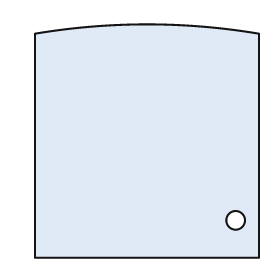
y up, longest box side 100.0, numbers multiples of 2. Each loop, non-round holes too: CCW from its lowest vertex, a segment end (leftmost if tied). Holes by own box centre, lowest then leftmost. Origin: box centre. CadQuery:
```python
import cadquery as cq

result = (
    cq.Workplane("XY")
    .moveTo(-48.0, -50.0)
    .lineTo(48.0, -50.0)
    .lineTo(48.0, 46.0)
    .threePointArc((0.0, 50.0), (-48.0, 46.0))
    .close()
    .moveTo(38.0, -34.0)
    .circle(4.0)
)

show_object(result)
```